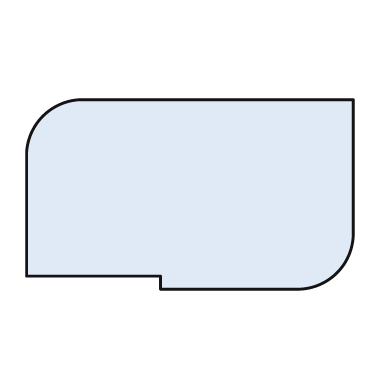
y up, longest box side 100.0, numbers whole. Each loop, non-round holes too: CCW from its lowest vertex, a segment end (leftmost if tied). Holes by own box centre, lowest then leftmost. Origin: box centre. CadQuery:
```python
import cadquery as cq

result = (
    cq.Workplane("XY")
    .moveTo(-9.0, -29.0)
    .lineTo(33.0, -29.0)
    .threePointArc((45.0, -24.0), (50.0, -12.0))
    .lineTo(50.0, 29.0)
    .lineTo(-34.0, 29.0)
    .threePointArc((-45.0, 24.0), (-50.0, 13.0))
    .lineTo(-50.0, -25.0)
    .lineTo(-9.0, -25.0)
    .close()
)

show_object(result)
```